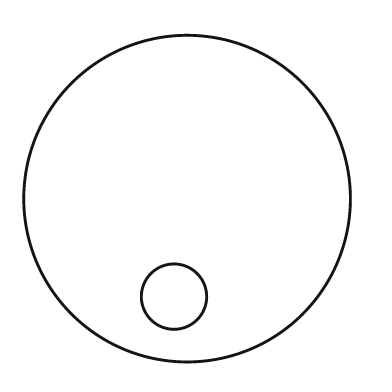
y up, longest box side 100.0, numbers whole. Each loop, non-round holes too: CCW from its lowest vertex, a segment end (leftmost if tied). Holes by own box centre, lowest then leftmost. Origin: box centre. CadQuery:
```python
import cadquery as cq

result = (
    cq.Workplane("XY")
    .moveTo(0.0, 0.0)
    .circle(50.0)
    .moveTo(-4.0, -30.0)
    .circle(10.0)
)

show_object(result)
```